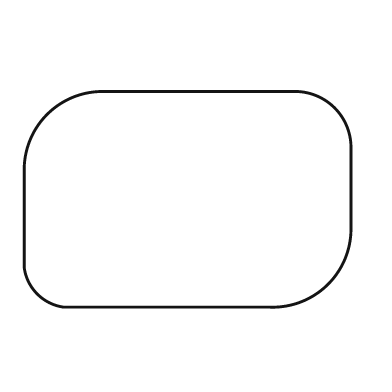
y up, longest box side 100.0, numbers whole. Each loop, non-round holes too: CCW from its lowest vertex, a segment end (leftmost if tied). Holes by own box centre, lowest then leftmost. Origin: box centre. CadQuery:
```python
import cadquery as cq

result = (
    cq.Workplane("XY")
    .moveTo(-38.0, -33.0)
    .lineTo(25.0, -33.0)
    .threePointArc((43.0, -26.0), (50.0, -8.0))
    .lineTo(50.0, 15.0)
    .threePointArc((45.0, 28.0), (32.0, 33.0))
    .lineTo(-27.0, 33.0)
    .threePointArc((-43.0, 26.0), (-50.0, 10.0))
    .lineTo(-50.0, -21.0)
    .threePointArc((-46.0, -29.0), (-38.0, -33.0))
    .close()
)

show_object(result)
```